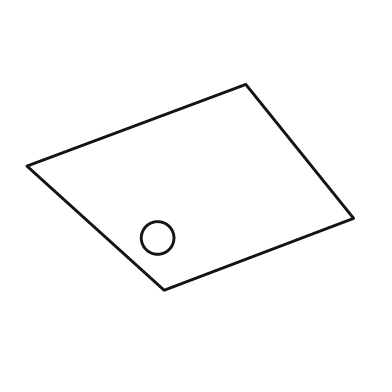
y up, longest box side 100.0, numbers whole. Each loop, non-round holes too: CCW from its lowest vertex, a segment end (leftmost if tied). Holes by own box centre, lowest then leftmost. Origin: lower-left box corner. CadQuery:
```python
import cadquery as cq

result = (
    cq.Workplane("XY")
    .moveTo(42.0, 0.0)
    .lineTo(100.0, 22.0)
    .lineTo(67.0, 63.0)
    .lineTo(0.0, 38.0)
    .close()
    .moveTo(40.0, 16.0)
    .circle(5.0)
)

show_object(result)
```